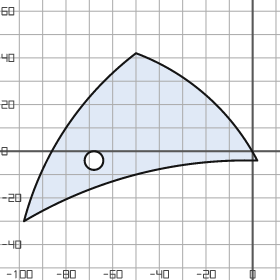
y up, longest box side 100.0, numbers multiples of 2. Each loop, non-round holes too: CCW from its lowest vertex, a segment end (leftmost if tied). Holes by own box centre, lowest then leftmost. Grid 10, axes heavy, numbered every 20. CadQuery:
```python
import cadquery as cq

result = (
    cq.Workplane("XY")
    .moveTo(-98.0, -30.0)
    .threePointArc((-50.0, -10.0), (2.0, -4.0))
    .threePointArc((-20.0, 24.0), (-50.0, 42.0))
    .threePointArc((-80.0, 10.0), (-98.0, -30.0))
    .close()
    .moveTo(-68.0, -4.0)
    .circle(4.0)
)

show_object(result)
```